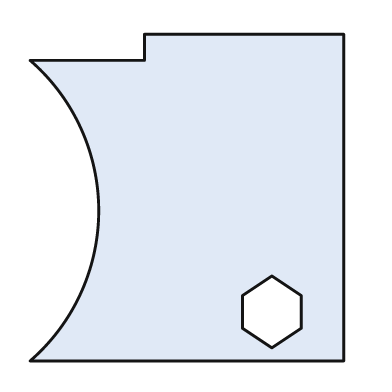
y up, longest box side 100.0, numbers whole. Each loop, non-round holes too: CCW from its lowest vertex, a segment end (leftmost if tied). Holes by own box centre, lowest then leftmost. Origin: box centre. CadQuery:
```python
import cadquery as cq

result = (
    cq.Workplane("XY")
    .moveTo(-48.0, -50.0)
    .lineTo(48.0, -50.0)
    .lineTo(48.0, 50.0)
    .lineTo(-13.0, 50.0)
    .lineTo(-13.0, 42.0)
    .lineTo(-48.0, 42.0)
    .threePointArc((-27.0, -4.0), (-48.0, -50.0))
    .close()
    .moveTo(26.0, -46.0)
    .lineTo(35.0, -40.0)
    .lineTo(35.0, -30.0)
    .lineTo(26.0, -24.0)
    .lineTo(17.0, -30.0)
    .lineTo(17.0, -40.0)
    .close()
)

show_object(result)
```